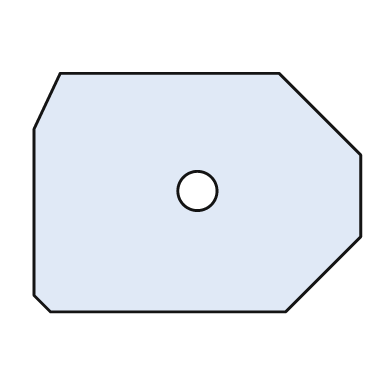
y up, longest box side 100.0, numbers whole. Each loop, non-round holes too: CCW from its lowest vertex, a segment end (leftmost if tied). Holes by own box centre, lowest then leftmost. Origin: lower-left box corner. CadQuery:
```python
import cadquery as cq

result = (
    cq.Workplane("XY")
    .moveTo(5.0, 0.0)
    .lineTo(77.0, 0.0)
    .lineTo(100.0, 23.0)
    .lineTo(100.0, 48.0)
    .lineTo(75.0, 73.0)
    .lineTo(8.0, 73.0)
    .lineTo(0.0, 56.0)
    .lineTo(0.0, 5.0)
    .close()
    .moveTo(50.0, 37.0)
    .circle(6.0)
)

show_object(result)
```